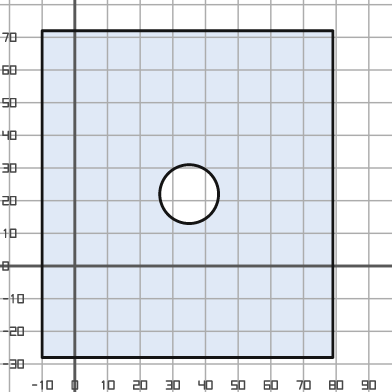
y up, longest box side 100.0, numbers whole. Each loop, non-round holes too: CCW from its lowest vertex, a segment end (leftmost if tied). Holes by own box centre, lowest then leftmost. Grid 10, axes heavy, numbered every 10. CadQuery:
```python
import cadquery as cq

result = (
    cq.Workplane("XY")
    .moveTo(-10.0, -28.0)
    .lineTo(79.0, -28.0)
    .lineTo(79.0, 72.0)
    .lineTo(-10.0, 72.0)
    .close()
    .moveTo(35.0, 22.0)
    .circle(9.0)
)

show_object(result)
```